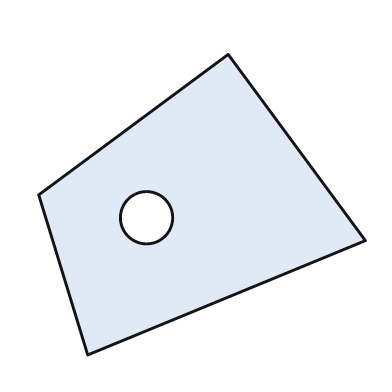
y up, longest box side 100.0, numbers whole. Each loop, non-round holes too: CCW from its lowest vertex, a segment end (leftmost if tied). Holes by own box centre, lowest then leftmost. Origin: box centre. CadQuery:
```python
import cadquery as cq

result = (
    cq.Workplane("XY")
    .moveTo(-35.0, -46.0)
    .lineTo(50.0, -11.0)
    .lineTo(8.0, 46.0)
    .lineTo(-50.0, 3.0)
    .close()
    .moveTo(-17.0, -4.0)
    .circle(8.0)
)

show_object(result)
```